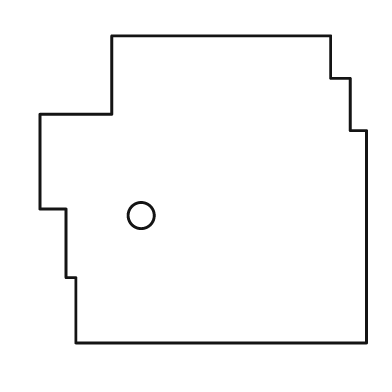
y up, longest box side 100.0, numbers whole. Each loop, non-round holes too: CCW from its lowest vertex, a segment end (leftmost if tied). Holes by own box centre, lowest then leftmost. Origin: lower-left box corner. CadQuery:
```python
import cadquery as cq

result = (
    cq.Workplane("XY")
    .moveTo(11.0, 0.0)
    .lineTo(100.0, 0.0)
    .lineTo(100.0, 65.0)
    .lineTo(95.0, 65.0)
    .lineTo(95.0, 81.0)
    .lineTo(89.0, 81.0)
    .lineTo(89.0, 94.0)
    .lineTo(22.0, 94.0)
    .lineTo(22.0, 70.0)
    .lineTo(0.0, 70.0)
    .lineTo(0.0, 41.0)
    .lineTo(8.0, 41.0)
    .lineTo(8.0, 20.0)
    .lineTo(11.0, 20.0)
    .close()
    .moveTo(31.0, 39.0)
    .circle(4.0)
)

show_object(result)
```